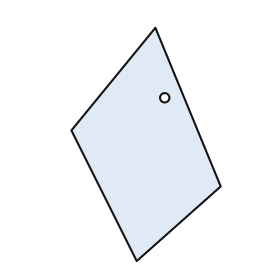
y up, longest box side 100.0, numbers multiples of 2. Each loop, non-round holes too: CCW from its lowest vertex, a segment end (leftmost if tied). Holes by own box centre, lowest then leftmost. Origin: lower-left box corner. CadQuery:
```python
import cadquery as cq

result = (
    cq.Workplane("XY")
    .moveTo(28.0, 0.0)
    .lineTo(64.0, 32.0)
    .lineTo(36.0, 100.0)
    .lineTo(0.0, 56.0)
    .close()
    .moveTo(40.0, 70.0)
    .circle(2.0)
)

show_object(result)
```